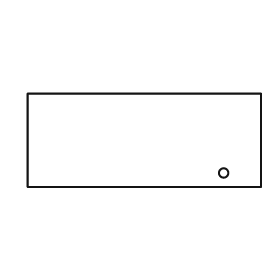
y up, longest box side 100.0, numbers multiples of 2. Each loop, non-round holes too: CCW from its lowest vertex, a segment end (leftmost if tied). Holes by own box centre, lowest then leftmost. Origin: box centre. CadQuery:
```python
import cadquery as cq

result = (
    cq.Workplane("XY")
    .moveTo(-50.0, -20.0)
    .lineTo(50.0, -20.0)
    .lineTo(50.0, 20.0)
    .lineTo(-50.0, 20.0)
    .close()
    .moveTo(34.0, -14.0)
    .circle(2.0)
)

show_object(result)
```